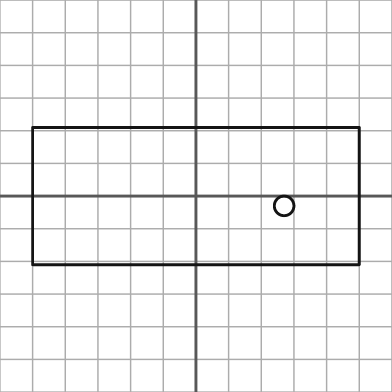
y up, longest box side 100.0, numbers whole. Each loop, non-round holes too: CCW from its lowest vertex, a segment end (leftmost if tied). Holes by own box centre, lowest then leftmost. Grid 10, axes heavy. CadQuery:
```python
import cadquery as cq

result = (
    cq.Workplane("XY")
    .moveTo(-50.0, -21.0)
    .lineTo(50.0, -21.0)
    .lineTo(50.0, 21.0)
    .lineTo(-50.0, 21.0)
    .close()
    .moveTo(27.0, -3.0)
    .circle(3.0)
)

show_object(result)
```